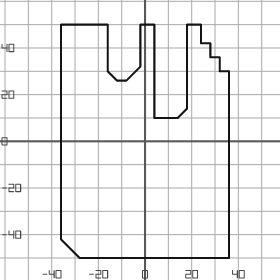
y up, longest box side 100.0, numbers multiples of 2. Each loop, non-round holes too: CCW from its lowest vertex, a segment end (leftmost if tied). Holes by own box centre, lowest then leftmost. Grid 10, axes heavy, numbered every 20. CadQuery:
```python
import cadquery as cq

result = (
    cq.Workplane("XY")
    .moveTo(-28.0, -50.0)
    .lineTo(36.0, -50.0)
    .lineTo(36.0, 30.0)
    .lineTo(32.0, 30.0)
    .lineTo(32.0, 36.0)
    .lineTo(28.0, 36.0)
    .lineTo(28.0, 42.0)
    .lineTo(24.0, 42.0)
    .lineTo(24.0, 50.0)
    .lineTo(18.0, 50.0)
    .lineTo(18.0, 14.0)
    .lineTo(14.0, 10.0)
    .lineTo(4.0, 10.0)
    .lineTo(4.0, 50.0)
    .lineTo(-2.0, 50.0)
    .lineTo(-2.0, 32.0)
    .lineTo(-8.0, 26.0)
    .lineTo(-12.0, 26.0)
    .lineTo(-16.0, 30.0)
    .lineTo(-16.0, 50.0)
    .lineTo(-36.0, 50.0)
    .lineTo(-36.0, -42.0)
    .close()
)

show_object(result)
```